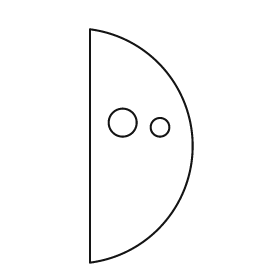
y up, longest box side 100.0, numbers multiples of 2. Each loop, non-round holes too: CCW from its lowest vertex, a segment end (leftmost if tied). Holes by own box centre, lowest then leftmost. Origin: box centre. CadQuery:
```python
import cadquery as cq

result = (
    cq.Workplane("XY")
    .moveTo(-22.0, -50.0)
    .threePointArc((22.0, 0.0), (-22.0, 50.0))
    .close()
    .moveTo(8.0, 8.0)
    .circle(4.0)
    .moveTo(-8.0, 10.0)
    .circle(6.0)
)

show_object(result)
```